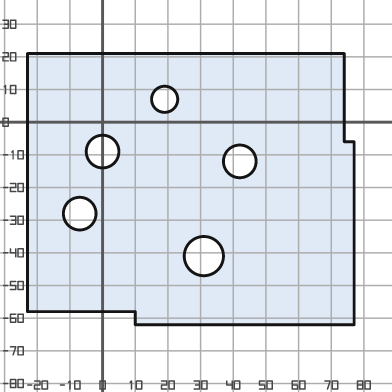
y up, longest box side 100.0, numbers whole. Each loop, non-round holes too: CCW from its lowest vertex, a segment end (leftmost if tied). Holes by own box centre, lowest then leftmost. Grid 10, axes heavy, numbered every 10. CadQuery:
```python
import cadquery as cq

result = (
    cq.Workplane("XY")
    .moveTo(10.0, -62.0)
    .lineTo(77.0, -62.0)
    .lineTo(77.0, -6.0)
    .lineTo(74.0, -6.0)
    .lineTo(74.0, 21.0)
    .lineTo(-23.0, 21.0)
    .lineTo(-23.0, -58.0)
    .lineTo(10.0, -58.0)
    .close()
    .moveTo(31.0, -41.0)
    .circle(6.0)
    .moveTo(-7.0, -28.0)
    .circle(5.0)
    .moveTo(42.0, -12.0)
    .circle(5.0)
    .moveTo(0.0, -9.0)
    .circle(5.0)
    .moveTo(19.0, 7.0)
    .circle(4.0)
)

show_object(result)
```